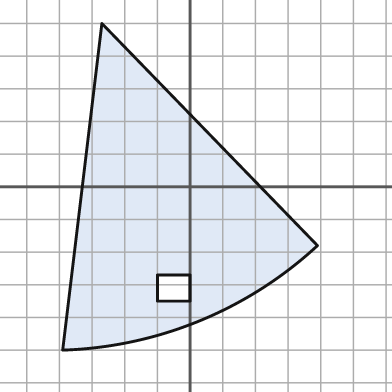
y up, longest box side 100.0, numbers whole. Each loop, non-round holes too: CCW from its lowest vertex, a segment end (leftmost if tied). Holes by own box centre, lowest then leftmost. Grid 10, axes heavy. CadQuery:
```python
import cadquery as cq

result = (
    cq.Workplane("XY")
    .moveTo(-39.0, -50.0)
    .threePointArc((3.0, -41.0), (39.0, -18.0))
    .lineTo(-27.0, 50.0)
    .close()
    .moveTo(-10.0, -35.0)
    .lineTo(0.0, -35.0)
    .lineTo(0.0, -27.0)
    .lineTo(-10.0, -27.0)
    .close()
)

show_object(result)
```